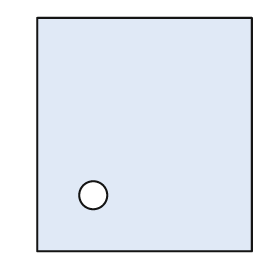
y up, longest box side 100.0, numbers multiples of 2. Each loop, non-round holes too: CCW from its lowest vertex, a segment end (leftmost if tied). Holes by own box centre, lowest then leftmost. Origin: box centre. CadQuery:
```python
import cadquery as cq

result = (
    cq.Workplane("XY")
    .moveTo(-46.0, -50.0)
    .lineTo(46.0, -50.0)
    .lineTo(46.0, 50.0)
    .lineTo(-46.0, 50.0)
    .close()
    .moveTo(-22.0, -26.0)
    .circle(6.0)
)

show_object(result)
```